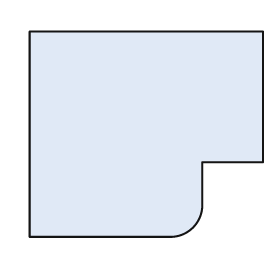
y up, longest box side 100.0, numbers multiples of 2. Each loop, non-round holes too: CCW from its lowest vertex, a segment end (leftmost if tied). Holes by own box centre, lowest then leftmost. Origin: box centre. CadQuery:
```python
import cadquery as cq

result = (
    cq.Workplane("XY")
    .moveTo(-50.0, -44.0)
    .lineTo(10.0, -44.0)
    .threePointArc((20.0, -40.0), (24.0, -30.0))
    .lineTo(24.0, -12.0)
    .lineTo(50.0, -12.0)
    .lineTo(50.0, 44.0)
    .lineTo(-50.0, 44.0)
    .close()
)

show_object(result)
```